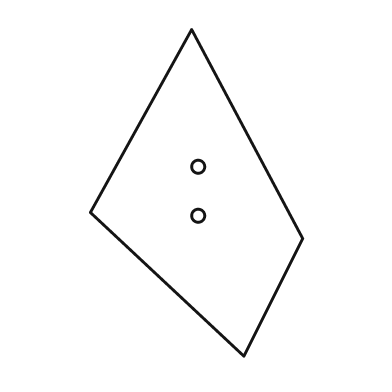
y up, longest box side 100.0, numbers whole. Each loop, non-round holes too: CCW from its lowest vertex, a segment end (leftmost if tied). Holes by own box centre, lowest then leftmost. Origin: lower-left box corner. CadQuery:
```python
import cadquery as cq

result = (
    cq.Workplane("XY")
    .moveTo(47.0, 0.0)
    .lineTo(65.0, 36.0)
    .lineTo(31.0, 100.0)
    .lineTo(0.0, 44.0)
    .close()
    .moveTo(33.0, 43.0)
    .circle(2.0)
    .moveTo(33.0, 58.0)
    .circle(2.0)
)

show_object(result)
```